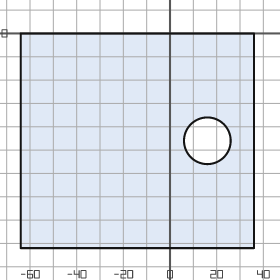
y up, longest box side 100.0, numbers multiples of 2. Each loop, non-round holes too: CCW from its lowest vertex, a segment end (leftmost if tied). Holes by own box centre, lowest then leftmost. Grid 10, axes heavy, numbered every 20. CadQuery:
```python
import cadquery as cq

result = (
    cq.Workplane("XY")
    .moveTo(-64.0, -92.0)
    .lineTo(36.0, -92.0)
    .lineTo(36.0, 0.0)
    .lineTo(-64.0, 0.0)
    .close()
    .moveTo(16.0, -46.0)
    .circle(10.0)
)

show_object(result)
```